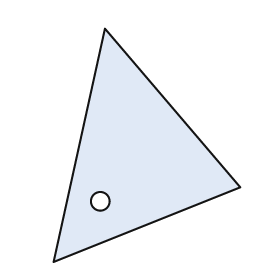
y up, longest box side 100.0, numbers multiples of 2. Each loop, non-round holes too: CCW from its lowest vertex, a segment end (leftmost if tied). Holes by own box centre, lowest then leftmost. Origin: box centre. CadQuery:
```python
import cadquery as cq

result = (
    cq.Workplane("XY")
    .moveTo(-40.0, -50.0)
    .lineTo(40.0, -18.0)
    .lineTo(-18.0, 50.0)
    .close()
    .moveTo(-20.0, -24.0)
    .circle(4.0)
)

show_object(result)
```